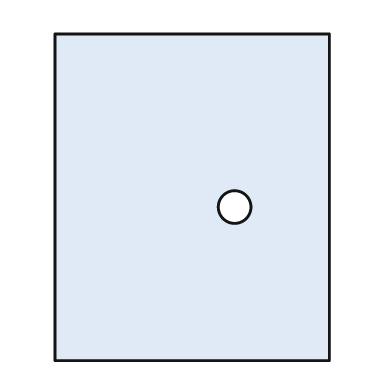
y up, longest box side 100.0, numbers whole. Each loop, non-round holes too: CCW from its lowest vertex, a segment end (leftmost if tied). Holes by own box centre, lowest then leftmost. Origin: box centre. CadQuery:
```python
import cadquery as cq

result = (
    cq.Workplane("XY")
    .moveTo(-42.0, -50.0)
    .lineTo(42.0, -50.0)
    .lineTo(42.0, 50.0)
    .lineTo(-42.0, 50.0)
    .close()
    .moveTo(13.0, -3.0)
    .circle(5.0)
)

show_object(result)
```